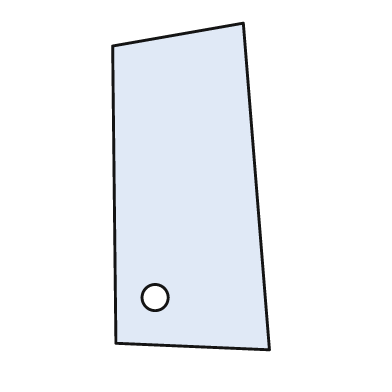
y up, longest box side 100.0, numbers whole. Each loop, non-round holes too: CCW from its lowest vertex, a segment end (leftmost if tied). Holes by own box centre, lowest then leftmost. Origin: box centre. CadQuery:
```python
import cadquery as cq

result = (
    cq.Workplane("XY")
    .moveTo(24.0, -50.0)
    .lineTo(16.0, 50.0)
    .lineTo(-24.0, 43.0)
    .lineTo(-23.0, -48.0)
    .close()
    .moveTo(-11.0, -34.0)
    .circle(4.0)
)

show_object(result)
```